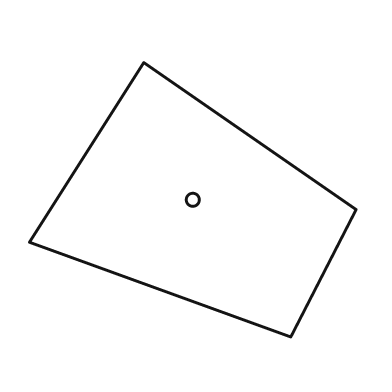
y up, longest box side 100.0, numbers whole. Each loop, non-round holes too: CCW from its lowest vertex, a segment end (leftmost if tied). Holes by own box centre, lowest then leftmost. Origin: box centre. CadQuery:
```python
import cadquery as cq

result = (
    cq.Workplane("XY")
    .moveTo(30.0, -42.0)
    .lineTo(50.0, -3.0)
    .lineTo(-15.0, 42.0)
    .lineTo(-50.0, -13.0)
    .close()
    .moveTo(0.0, 0.0)
    .circle(2.0)
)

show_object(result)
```